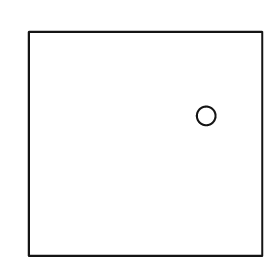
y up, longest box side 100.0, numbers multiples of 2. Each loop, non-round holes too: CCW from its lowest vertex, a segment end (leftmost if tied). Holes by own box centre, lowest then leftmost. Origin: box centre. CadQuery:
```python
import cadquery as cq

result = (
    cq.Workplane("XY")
    .moveTo(-50.0, -48.0)
    .lineTo(50.0, -48.0)
    .lineTo(50.0, 48.0)
    .lineTo(-50.0, 48.0)
    .close()
    .moveTo(26.0, 12.0)
    .circle(4.0)
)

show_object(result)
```